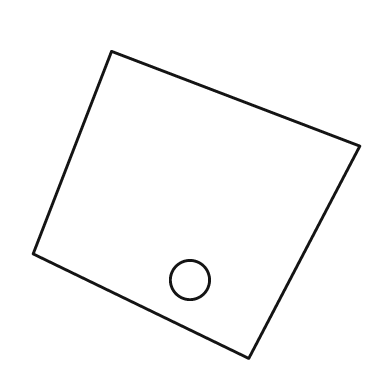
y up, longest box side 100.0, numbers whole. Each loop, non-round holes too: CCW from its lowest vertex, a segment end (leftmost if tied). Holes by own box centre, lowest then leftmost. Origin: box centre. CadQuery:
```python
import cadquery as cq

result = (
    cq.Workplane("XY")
    .moveTo(16.0, -47.0)
    .lineTo(50.0, 18.0)
    .lineTo(-26.0, 47.0)
    .lineTo(-50.0, -15.0)
    .close()
    .moveTo(-2.0, -23.0)
    .circle(6.0)
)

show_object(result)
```